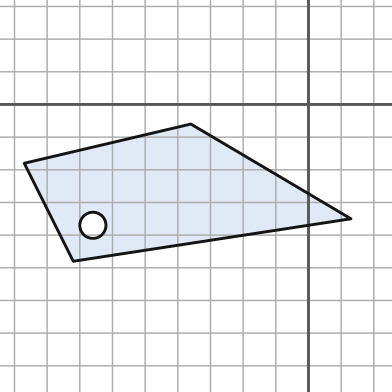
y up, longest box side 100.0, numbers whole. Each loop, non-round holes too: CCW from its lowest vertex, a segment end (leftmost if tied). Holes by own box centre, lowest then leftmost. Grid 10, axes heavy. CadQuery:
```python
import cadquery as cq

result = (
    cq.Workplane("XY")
    .moveTo(-72.0, -48.0)
    .lineTo(13.0, -35.0)
    .lineTo(-36.0, -6.0)
    .lineTo(-87.0, -18.0)
    .close()
    .moveTo(-66.0, -37.0)
    .circle(4.0)
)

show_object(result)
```